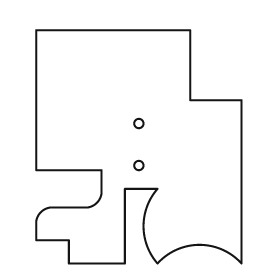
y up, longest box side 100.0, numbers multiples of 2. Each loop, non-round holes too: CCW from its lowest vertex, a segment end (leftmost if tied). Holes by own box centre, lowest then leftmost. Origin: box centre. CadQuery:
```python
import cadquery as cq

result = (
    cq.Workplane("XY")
    .moveTo(-30.0, -50.0)
    .lineTo(-6.0, -50.0)
    .lineTo(-6.0, -18.0)
    .lineTo(8.0, -18.0)
    .threePointArc((2.0, -34.0), (8.0, -50.0))
    .threePointArc((26.0, -42.0), (44.0, -50.0))
    .lineTo(44.0, 20.0)
    .lineTo(22.0, 20.0)
    .lineTo(22.0, 50.0)
    .lineTo(-44.0, 50.0)
    .lineTo(-44.0, -10.0)
    .lineTo(-16.0, -10.0)
    .lineTo(-16.0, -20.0)
    .threePointArc((-18.0, -24.0), (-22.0, -26.0))
    .lineTo(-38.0, -26.0)
    .threePointArc((-42.0, -28.0), (-44.0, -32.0))
    .lineTo(-44.0, -40.0)
    .lineTo(-30.0, -40.0)
    .close()
    .moveTo(0.0, -8.0)
    .circle(2.0)
    .moveTo(0.0, 10.0)
    .circle(2.0)
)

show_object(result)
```